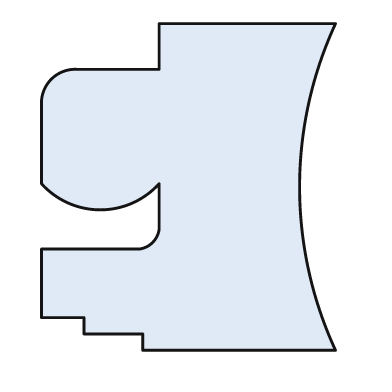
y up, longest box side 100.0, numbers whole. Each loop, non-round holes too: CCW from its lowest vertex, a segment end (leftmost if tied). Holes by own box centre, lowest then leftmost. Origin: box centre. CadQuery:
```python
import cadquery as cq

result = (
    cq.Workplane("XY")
    .moveTo(-14.0, -50.0)
    .lineTo(45.0, -50.0)
    .threePointArc((34.0, 0.0), (45.0, 50.0))
    .lineTo(-9.0, 50.0)
    .lineTo(-9.0, 36.0)
    .lineTo(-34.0, 36.0)
    .threePointArc((-42.0, 33.0), (-45.0, 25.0))
    .lineTo(-45.0, 1.0)
    .threePointArc((-27.0, -7.0), (-9.0, 1.0))
    .lineTo(-9.0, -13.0)
    .threePointArc((-11.0, -17.0), (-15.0, -19.0))
    .lineTo(-45.0, -19.0)
    .lineTo(-45.0, -40.0)
    .lineTo(-32.0, -40.0)
    .lineTo(-32.0, -45.0)
    .lineTo(-14.0, -45.0)
    .close()
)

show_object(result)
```